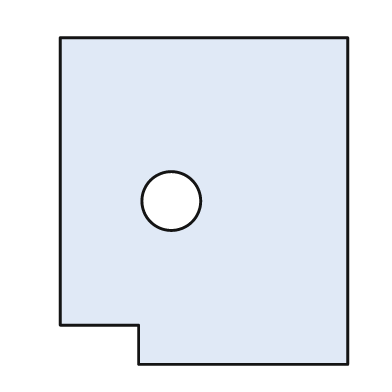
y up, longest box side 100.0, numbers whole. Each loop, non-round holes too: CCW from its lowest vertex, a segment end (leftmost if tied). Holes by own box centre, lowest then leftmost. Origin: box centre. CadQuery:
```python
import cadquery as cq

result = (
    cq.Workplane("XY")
    .moveTo(-20.0, -50.0)
    .lineTo(44.0, -50.0)
    .lineTo(44.0, 50.0)
    .lineTo(-44.0, 50.0)
    .lineTo(-44.0, -38.0)
    .lineTo(-20.0, -38.0)
    .close()
    .moveTo(-10.0, 0.0)
    .circle(9.0)
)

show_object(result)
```